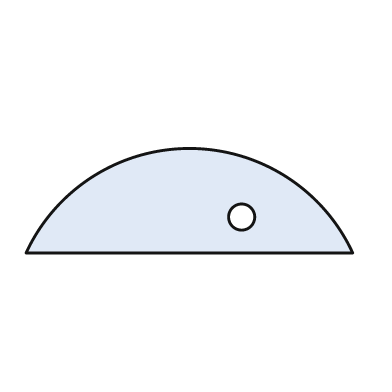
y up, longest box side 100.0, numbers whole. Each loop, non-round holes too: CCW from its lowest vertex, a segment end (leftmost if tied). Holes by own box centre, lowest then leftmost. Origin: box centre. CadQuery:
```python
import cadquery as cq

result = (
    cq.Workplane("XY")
    .moveTo(-50.0, -16.0)
    .lineTo(50.0, -16.0)
    .threePointArc((0.0, 16.0), (-50.0, -16.0))
    .close()
    .moveTo(16.0, -5.0)
    .circle(4.0)
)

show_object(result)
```